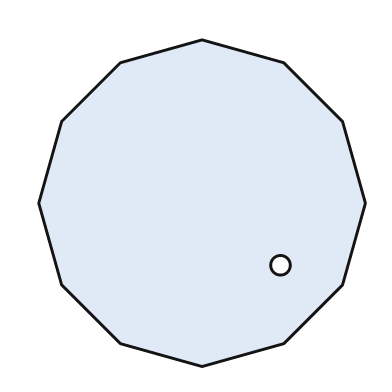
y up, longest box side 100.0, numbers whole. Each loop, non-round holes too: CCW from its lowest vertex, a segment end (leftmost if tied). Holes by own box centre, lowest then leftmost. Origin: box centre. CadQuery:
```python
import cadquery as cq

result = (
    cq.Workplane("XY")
    .moveTo(0.0, -50.0)
    .lineTo(25.0, -43.0)
    .lineTo(43.0, -25.0)
    .lineTo(50.0, 0.0)
    .lineTo(43.0, 25.0)
    .lineTo(25.0, 43.0)
    .lineTo(0.0, 50.0)
    .lineTo(-25.0, 43.0)
    .lineTo(-43.0, 25.0)
    .lineTo(-50.0, 0.0)
    .lineTo(-43.0, -25.0)
    .lineTo(-25.0, -43.0)
    .close()
    .moveTo(24.0, -19.0)
    .circle(3.0)
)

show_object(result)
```